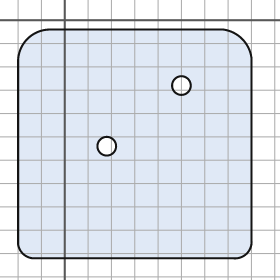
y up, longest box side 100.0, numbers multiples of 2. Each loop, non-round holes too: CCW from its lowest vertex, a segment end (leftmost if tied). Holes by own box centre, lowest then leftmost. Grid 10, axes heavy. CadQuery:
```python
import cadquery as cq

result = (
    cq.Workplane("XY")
    .moveTo(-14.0, -102.0)
    .lineTo(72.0, -102.0)
    .threePointArc((78.0, -100.0), (80.0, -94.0))
    .lineTo(80.0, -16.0)
    .threePointArc((76.0, -8.0), (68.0, -4.0))
    .lineTo(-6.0, -4.0)
    .threePointArc((-16.0, -8.0), (-20.0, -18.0))
    .lineTo(-20.0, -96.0)
    .threePointArc((-18.0, -100.0), (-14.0, -102.0))
    .close()
    .moveTo(18.0, -54.0)
    .circle(4.0)
    .moveTo(50.0, -28.0)
    .circle(4.0)
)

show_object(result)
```